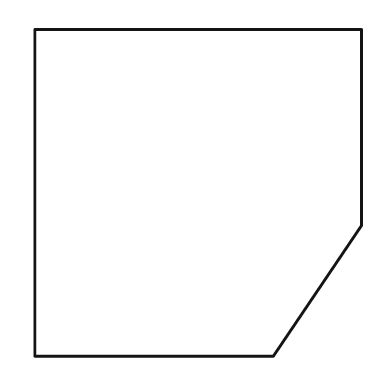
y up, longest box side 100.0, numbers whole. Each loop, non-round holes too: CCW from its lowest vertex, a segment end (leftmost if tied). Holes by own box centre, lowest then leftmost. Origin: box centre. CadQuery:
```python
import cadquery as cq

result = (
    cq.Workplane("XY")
    .moveTo(-50.0, -50.0)
    .lineTo(23.0, -50.0)
    .lineTo(50.0, -10.0)
    .lineTo(50.0, 50.0)
    .lineTo(-50.0, 50.0)
    .close()
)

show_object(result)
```